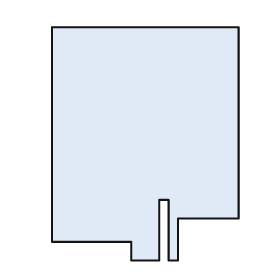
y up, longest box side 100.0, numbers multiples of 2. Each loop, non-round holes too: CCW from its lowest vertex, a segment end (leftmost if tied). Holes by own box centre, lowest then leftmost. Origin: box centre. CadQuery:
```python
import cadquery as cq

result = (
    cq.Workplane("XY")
    .moveTo(-6.0, -50.0)
    .lineTo(6.0, -50.0)
    .lineTo(6.0, -24.0)
    .lineTo(10.0, -24.0)
    .lineTo(10.0, -50.0)
    .lineTo(14.0, -50.0)
    .lineTo(14.0, -32.0)
    .lineTo(40.0, -32.0)
    .lineTo(40.0, 50.0)
    .lineTo(-40.0, 50.0)
    .lineTo(-40.0, -42.0)
    .lineTo(-6.0, -42.0)
    .close()
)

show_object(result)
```